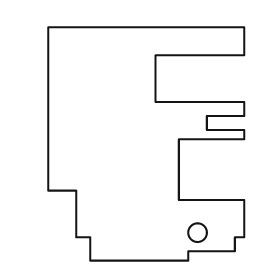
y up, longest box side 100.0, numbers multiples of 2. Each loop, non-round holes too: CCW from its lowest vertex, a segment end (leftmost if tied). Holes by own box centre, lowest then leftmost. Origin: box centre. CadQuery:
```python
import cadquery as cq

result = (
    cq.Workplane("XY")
    .moveTo(-24.0, -50.0)
    .lineTo(18.0, -50.0)
    .lineTo(18.0, -46.0)
    .lineTo(38.0, -46.0)
    .lineTo(38.0, -40.0)
    .lineTo(42.0, -40.0)
    .lineTo(42.0, -24.0)
    .lineTo(14.0, -24.0)
    .lineTo(14.0, 2.0)
    .lineTo(42.0, 2.0)
    .lineTo(42.0, 6.0)
    .lineTo(26.0, 6.0)
    .lineTo(26.0, 12.0)
    .lineTo(42.0, 12.0)
    .lineTo(42.0, 18.0)
    .lineTo(4.0, 18.0)
    .lineTo(4.0, 38.0)
    .lineTo(42.0, 38.0)
    .lineTo(42.0, 50.0)
    .lineTo(-42.0, 50.0)
    .lineTo(-42.0, -20.0)
    .lineTo(-30.0, -20.0)
    .lineTo(-30.0, -40.0)
    .lineTo(-24.0, -40.0)
    .close()
    .moveTo(22.0, -38.0)
    .circle(4.0)
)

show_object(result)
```